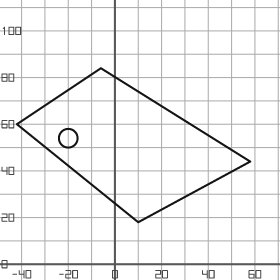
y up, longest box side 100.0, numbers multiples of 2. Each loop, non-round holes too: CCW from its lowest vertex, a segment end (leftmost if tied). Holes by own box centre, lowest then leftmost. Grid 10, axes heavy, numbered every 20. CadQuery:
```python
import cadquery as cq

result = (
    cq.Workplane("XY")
    .moveTo(10.0, 18.0)
    .lineTo(58.0, 44.0)
    .lineTo(-6.0, 84.0)
    .lineTo(-42.0, 60.0)
    .close()
    .moveTo(-20.0, 54.0)
    .circle(4.0)
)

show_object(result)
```